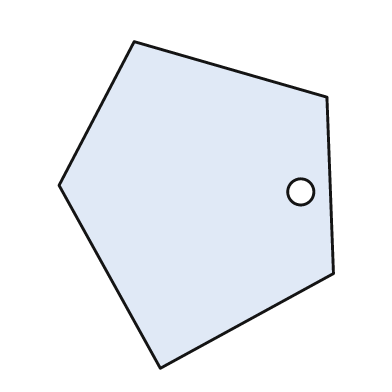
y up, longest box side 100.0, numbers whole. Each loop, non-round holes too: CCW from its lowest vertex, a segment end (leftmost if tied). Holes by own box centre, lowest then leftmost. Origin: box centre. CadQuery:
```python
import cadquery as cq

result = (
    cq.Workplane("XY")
    .moveTo(-11.0, -50.0)
    .lineTo(42.0, -21.0)
    .lineTo(40.0, 33.0)
    .lineTo(-19.0, 50.0)
    .lineTo(-42.0, 6.0)
    .close()
    .moveTo(32.0, 4.0)
    .circle(4.0)
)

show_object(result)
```